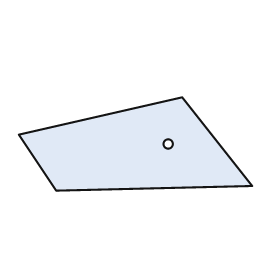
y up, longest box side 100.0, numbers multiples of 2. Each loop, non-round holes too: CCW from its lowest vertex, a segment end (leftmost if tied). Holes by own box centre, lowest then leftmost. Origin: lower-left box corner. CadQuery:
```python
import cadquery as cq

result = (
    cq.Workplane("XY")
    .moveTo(16.0, 0.0)
    .lineTo(100.0, 2.0)
    .lineTo(70.0, 40.0)
    .lineTo(0.0, 24.0)
    .close()
    .moveTo(64.0, 20.0)
    .circle(2.0)
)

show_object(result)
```